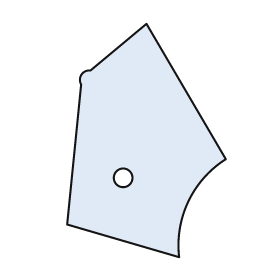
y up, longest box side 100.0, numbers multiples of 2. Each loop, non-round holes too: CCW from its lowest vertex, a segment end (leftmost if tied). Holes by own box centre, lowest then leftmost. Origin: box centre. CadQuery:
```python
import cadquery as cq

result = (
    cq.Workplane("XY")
    .moveTo(14.0, -50.0)
    .threePointArc((18.0, -26.0), (34.0, -8.0))
    .lineTo(0.0, 50.0)
    .lineTo(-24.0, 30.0)
    .threePointArc((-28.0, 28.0), (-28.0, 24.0))
    .lineTo(-34.0, -36.0)
    .close()
    .moveTo(-10.0, -16.0)
    .circle(4.0)
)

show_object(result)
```